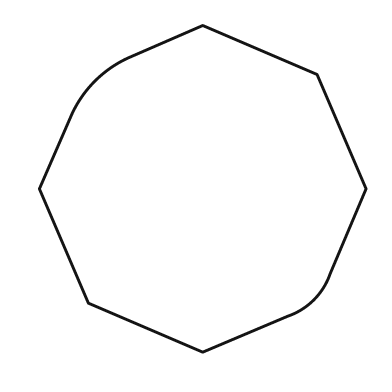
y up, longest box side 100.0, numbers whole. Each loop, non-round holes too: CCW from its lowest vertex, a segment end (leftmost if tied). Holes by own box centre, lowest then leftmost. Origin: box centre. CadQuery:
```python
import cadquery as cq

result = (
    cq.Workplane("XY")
    .moveTo(0.0, -50.0)
    .lineTo(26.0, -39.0)
    .threePointArc((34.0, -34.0), (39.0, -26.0))
    .lineTo(50.0, 0.0)
    .lineTo(35.0, 35.0)
    .lineTo(0.0, 50.0)
    .lineTo(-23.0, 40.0)
    .threePointArc((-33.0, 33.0), (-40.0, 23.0))
    .lineTo(-50.0, 0.0)
    .lineTo(-35.0, -35.0)
    .close()
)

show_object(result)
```